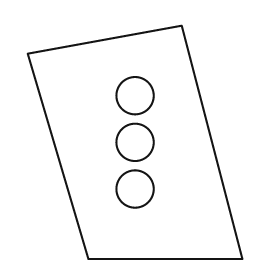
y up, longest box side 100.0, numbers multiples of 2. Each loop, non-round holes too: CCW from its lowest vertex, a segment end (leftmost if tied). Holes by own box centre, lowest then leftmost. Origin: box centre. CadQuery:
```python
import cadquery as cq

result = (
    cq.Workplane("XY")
    .moveTo(-20.0, -50.0)
    .lineTo(46.0, -50.0)
    .lineTo(20.0, 50.0)
    .lineTo(-46.0, 38.0)
    .close()
    .moveTo(0.0, -20.0)
    .circle(8.0)
    .moveTo(0.0, 0.0)
    .circle(8.0)
    .moveTo(0.0, 20.0)
    .circle(8.0)
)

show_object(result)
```